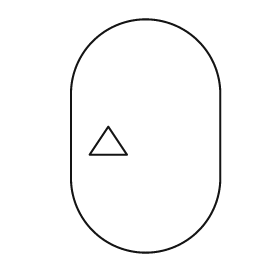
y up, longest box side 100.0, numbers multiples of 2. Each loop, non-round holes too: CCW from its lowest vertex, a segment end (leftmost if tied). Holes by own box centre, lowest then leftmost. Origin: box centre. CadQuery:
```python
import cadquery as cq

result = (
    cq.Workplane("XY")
    .moveTo(-32.0, -18.0)
    .threePointArc((0.0, -50.0), (32.0, -18.0))
    .lineTo(32.0, 18.0)
    .threePointArc((0.0, 50.0), (-32.0, 18.0))
    .close()
    .moveTo(-24.0, -8.0)
    .lineTo(-8.0, -8.0)
    .lineTo(-16.0, 4.0)
    .close()
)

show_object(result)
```